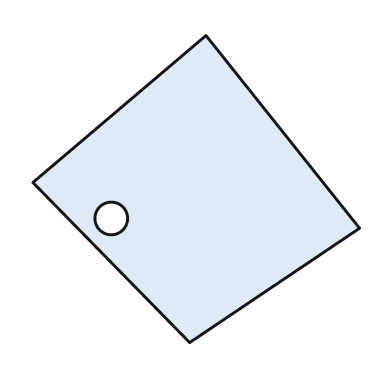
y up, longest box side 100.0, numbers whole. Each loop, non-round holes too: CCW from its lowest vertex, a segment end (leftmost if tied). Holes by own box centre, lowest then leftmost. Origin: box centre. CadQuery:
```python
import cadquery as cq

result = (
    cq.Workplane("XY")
    .moveTo(-2.0, -47.0)
    .lineTo(50.0, -12.0)
    .lineTo(3.0, 47.0)
    .lineTo(-50.0, 2.0)
    .close()
    .moveTo(-26.0, -9.0)
    .circle(5.0)
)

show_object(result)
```